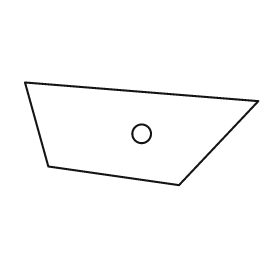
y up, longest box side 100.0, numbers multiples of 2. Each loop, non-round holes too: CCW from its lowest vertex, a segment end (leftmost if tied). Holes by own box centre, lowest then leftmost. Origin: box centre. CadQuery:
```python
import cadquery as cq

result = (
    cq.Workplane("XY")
    .moveTo(16.0, -22.0)
    .lineTo(50.0, 14.0)
    .lineTo(-50.0, 22.0)
    .lineTo(-40.0, -14.0)
    .close()
    .moveTo(0.0, 0.0)
    .circle(4.0)
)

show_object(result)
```